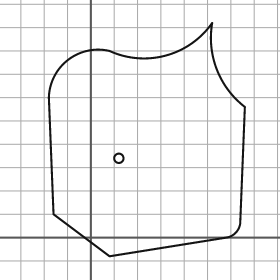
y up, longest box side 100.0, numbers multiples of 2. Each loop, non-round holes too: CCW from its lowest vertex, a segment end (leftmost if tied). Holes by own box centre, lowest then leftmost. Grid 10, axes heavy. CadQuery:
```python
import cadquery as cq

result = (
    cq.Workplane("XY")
    .moveTo(8.0, -8.0)
    .lineTo(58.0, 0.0)
    .threePointArc((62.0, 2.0), (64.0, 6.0))
    .lineTo(66.0, 56.0)
    .threePointArc((54.0, 72.0), (52.0, 92.0))
    .threePointArc((32.0, 78.0), (8.0, 80.0))
    .threePointArc((-10.0, 76.0), (-18.0, 60.0))
    .lineTo(-16.0, 10.0)
    .close()
    .moveTo(12.0, 34.0)
    .circle(2.0)
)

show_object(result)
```